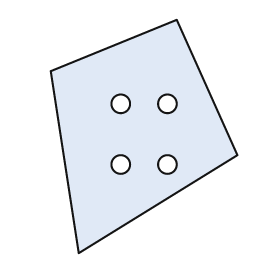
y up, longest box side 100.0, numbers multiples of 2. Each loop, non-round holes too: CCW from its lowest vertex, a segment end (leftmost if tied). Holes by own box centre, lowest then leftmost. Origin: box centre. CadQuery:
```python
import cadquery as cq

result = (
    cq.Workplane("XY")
    .moveTo(-28.0, -50.0)
    .lineTo(40.0, -8.0)
    .lineTo(14.0, 50.0)
    .lineTo(-40.0, 28.0)
    .close()
    .moveTo(-10.0, -12.0)
    .circle(4.0)
    .moveTo(10.0, -12.0)
    .circle(4.0)
    .moveTo(-10.0, 14.0)
    .circle(4.0)
    .moveTo(10.0, 14.0)
    .circle(4.0)
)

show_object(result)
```